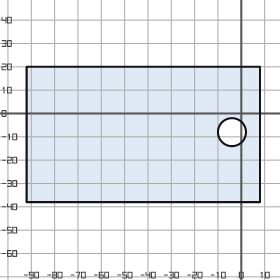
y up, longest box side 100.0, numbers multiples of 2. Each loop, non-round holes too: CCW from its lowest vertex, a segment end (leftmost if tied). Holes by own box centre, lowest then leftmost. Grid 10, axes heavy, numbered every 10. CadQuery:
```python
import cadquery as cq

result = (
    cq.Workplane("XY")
    .moveTo(-92.0, -38.0)
    .lineTo(8.0, -38.0)
    .lineTo(8.0, 20.0)
    .lineTo(-92.0, 20.0)
    .close()
    .moveTo(-4.0, -8.0)
    .circle(6.0)
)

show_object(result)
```